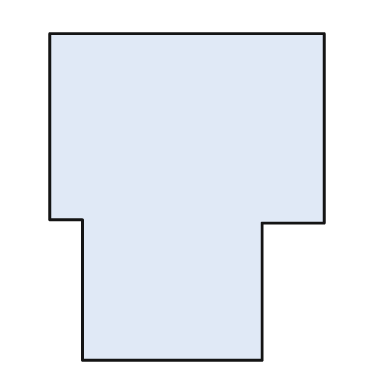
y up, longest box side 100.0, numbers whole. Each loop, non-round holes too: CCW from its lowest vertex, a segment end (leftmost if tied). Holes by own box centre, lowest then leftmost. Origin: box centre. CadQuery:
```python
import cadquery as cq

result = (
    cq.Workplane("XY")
    .moveTo(-32.0, -50.0)
    .lineTo(23.0, -50.0)
    .lineTo(23.0, -8.0)
    .lineTo(42.0, -8.0)
    .lineTo(42.0, 50.0)
    .lineTo(-42.0, 50.0)
    .lineTo(-42.0, -7.0)
    .lineTo(-32.0, -7.0)
    .close()
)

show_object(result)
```